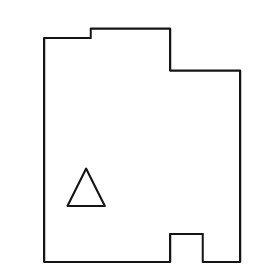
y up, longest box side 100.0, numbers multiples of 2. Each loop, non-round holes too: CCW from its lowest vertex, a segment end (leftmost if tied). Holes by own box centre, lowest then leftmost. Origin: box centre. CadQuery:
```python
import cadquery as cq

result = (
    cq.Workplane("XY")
    .moveTo(-42.0, -50.0)
    .lineTo(12.0, -50.0)
    .lineTo(12.0, -38.0)
    .lineTo(26.0, -38.0)
    .lineTo(26.0, -50.0)
    .lineTo(42.0, -50.0)
    .lineTo(42.0, 32.0)
    .lineTo(12.0, 32.0)
    .lineTo(12.0, 50.0)
    .lineTo(-22.0, 50.0)
    .lineTo(-22.0, 46.0)
    .lineTo(-42.0, 46.0)
    .close()
    .moveTo(-32.0, -26.0)
    .lineTo(-16.0, -26.0)
    .lineTo(-24.0, -10.0)
    .close()
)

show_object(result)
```